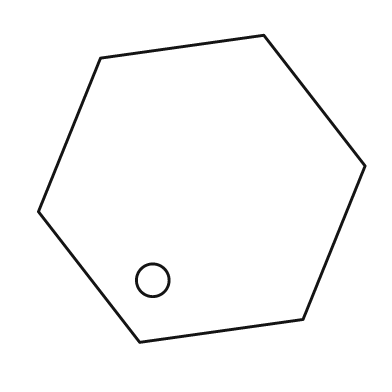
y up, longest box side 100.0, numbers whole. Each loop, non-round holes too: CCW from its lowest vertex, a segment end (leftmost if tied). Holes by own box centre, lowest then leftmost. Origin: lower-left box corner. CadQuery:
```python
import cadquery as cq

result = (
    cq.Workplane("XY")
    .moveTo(31.0, 0.0)
    .lineTo(81.0, 7.0)
    .lineTo(100.0, 54.0)
    .lineTo(69.0, 94.0)
    .lineTo(19.0, 87.0)
    .lineTo(0.0, 40.0)
    .close()
    .moveTo(35.0, 19.0)
    .circle(5.0)
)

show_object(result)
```